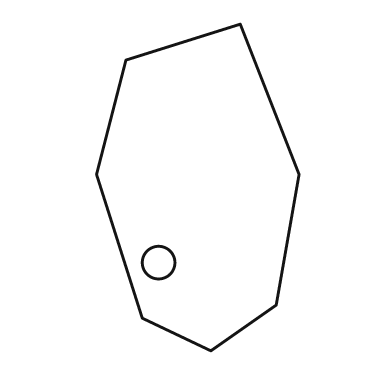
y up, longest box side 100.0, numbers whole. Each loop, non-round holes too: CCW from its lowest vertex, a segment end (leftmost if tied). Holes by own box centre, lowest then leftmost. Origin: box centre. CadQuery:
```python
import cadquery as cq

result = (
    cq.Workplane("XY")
    .moveTo(4.0, -50.0)
    .lineTo(24.0, -36.0)
    .lineTo(31.0, 4.0)
    .lineTo(13.0, 50.0)
    .lineTo(-22.0, 39.0)
    .lineTo(-31.0, 4.0)
    .lineTo(-17.0, -40.0)
    .close()
    .moveTo(-12.0, -23.0)
    .circle(5.0)
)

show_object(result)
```